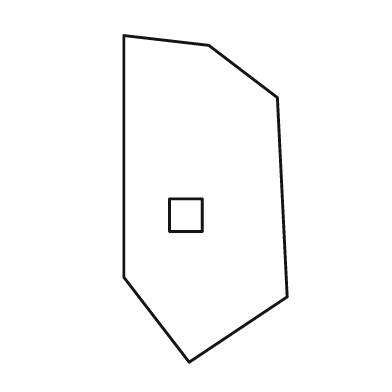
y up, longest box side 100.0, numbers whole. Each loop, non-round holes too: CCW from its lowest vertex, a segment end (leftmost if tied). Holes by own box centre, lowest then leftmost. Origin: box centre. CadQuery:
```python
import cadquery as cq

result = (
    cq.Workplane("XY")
    .moveTo(-5.0, -50.0)
    .lineTo(25.0, -30.0)
    .lineTo(22.0, 31.0)
    .lineTo(1.0, 47.0)
    .lineTo(-25.0, 50.0)
    .lineTo(-25.0, -24.0)
    .close()
    .moveTo(-11.0, -10.0)
    .lineTo(-1.0, -10.0)
    .lineTo(-1.0, 0.0)
    .lineTo(-11.0, 0.0)
    .close()
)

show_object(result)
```